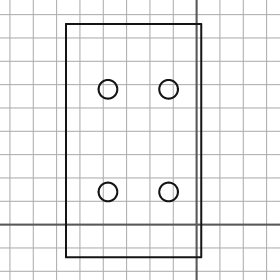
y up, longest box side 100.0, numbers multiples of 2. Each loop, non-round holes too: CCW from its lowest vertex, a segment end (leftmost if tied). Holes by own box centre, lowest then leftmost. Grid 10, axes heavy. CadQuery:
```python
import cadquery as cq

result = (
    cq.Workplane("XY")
    .moveTo(-56.0, -14.0)
    .lineTo(2.0, -14.0)
    .lineTo(2.0, 86.0)
    .lineTo(-56.0, 86.0)
    .close()
    .moveTo(-38.0, 14.0)
    .circle(4.0)
    .moveTo(-12.0, 14.0)
    .circle(4.0)
    .moveTo(-38.0, 58.0)
    .circle(4.0)
    .moveTo(-12.0, 58.0)
    .circle(4.0)
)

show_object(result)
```